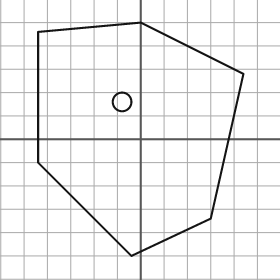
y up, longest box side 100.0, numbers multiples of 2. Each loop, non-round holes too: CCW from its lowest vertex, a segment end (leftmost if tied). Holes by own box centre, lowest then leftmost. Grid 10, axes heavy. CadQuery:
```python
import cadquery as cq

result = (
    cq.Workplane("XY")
    .moveTo(-4.0, -50.0)
    .lineTo(30.0, -34.0)
    .lineTo(44.0, 28.0)
    .lineTo(0.0, 50.0)
    .lineTo(-44.0, 46.0)
    .lineTo(-44.0, -10.0)
    .close()
    .moveTo(-8.0, 16.0)
    .circle(4.0)
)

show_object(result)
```